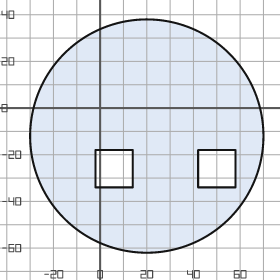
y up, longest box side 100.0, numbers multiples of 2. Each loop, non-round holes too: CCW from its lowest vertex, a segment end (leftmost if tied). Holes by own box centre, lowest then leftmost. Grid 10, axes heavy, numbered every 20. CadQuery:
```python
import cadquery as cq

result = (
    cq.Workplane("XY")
    .moveTo(20.0, -12.0)
    .circle(50.0)
    .moveTo(-2.0, -34.0)
    .lineTo(14.0, -34.0)
    .lineTo(14.0, -18.0)
    .lineTo(-2.0, -18.0)
    .close()
    .moveTo(42.0, -34.0)
    .lineTo(58.0, -34.0)
    .lineTo(58.0, -18.0)
    .lineTo(42.0, -18.0)
    .close()
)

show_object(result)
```